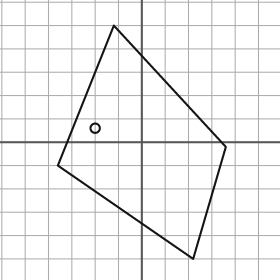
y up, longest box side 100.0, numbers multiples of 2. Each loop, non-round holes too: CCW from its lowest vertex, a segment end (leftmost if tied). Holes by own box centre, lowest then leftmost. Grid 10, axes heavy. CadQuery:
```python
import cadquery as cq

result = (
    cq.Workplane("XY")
    .moveTo(22.0, -50.0)
    .lineTo(36.0, -2.0)
    .lineTo(-12.0, 50.0)
    .lineTo(-36.0, -10.0)
    .close()
    .moveTo(-20.0, 6.0)
    .circle(2.0)
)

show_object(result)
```